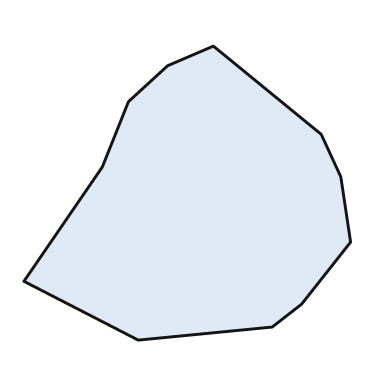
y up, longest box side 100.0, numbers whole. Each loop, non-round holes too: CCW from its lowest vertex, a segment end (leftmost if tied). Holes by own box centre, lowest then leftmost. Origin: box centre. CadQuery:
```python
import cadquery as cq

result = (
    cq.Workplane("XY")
    .moveTo(-15.0, -45.0)
    .lineTo(26.0, -41.0)
    .lineTo(35.0, -34.0)
    .lineTo(50.0, -15.0)
    .lineTo(47.0, 5.0)
    .lineTo(41.0, 18.0)
    .lineTo(8.0, 45.0)
    .lineTo(-6.0, 39.0)
    .lineTo(-18.0, 28.0)
    .lineTo(-26.0, 8.0)
    .lineTo(-50.0, -27.0)
    .close()
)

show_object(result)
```